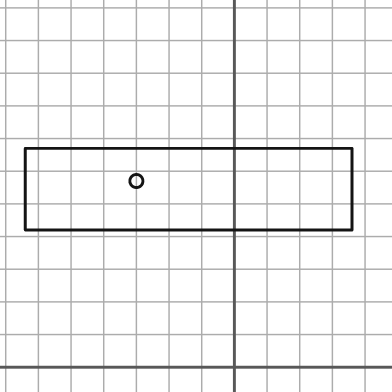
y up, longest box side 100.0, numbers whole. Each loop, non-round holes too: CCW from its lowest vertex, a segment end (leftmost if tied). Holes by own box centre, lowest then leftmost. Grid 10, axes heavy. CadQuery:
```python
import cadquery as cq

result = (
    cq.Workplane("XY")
    .moveTo(-64.0, 42.0)
    .lineTo(36.0, 42.0)
    .lineTo(36.0, 67.0)
    .lineTo(-64.0, 67.0)
    .close()
    .moveTo(-30.0, 57.0)
    .circle(2.0)
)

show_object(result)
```